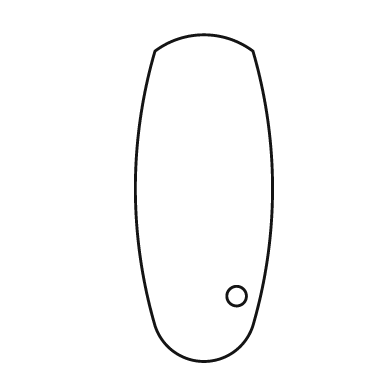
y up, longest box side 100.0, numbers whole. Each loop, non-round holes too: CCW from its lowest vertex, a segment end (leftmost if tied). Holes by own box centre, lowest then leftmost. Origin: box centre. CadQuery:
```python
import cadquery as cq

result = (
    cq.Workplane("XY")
    .moveTo(-15.0, -39.0)
    .threePointArc((0.0, -50.0), (15.0, -39.0))
    .threePointArc((21.0, 3.0), (15.0, 45.0))
    .threePointArc((0.0, 50.0), (-15.0, 45.0))
    .threePointArc((-21.0, 3.0), (-15.0, -39.0))
    .close()
    .moveTo(10.0, -30.0)
    .circle(3.0)
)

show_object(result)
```